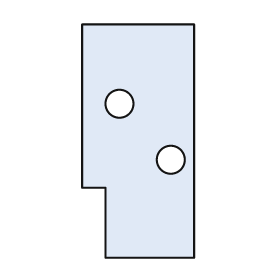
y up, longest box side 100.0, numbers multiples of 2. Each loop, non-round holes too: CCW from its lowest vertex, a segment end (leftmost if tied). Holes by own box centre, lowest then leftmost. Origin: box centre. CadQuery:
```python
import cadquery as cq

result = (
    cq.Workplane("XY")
    .moveTo(-14.0, -50.0)
    .lineTo(24.0, -50.0)
    .lineTo(24.0, 50.0)
    .lineTo(-24.0, 50.0)
    .lineTo(-24.0, -20.0)
    .lineTo(-14.0, -20.0)
    .close()
    .moveTo(14.0, -8.0)
    .circle(6.0)
    .moveTo(-8.0, 16.0)
    .circle(6.0)
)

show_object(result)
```